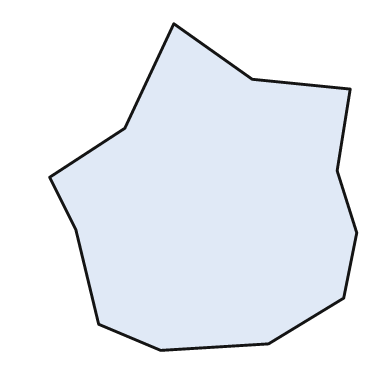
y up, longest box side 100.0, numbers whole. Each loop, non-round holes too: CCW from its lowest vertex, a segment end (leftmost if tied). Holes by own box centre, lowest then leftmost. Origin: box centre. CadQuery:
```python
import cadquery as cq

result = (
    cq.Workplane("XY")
    .moveTo(-13.0, -50.0)
    .lineTo(20.0, -48.0)
    .lineTo(43.0, -34.0)
    .lineTo(47.0, -14.0)
    .lineTo(41.0, 5.0)
    .lineTo(45.0, 30.0)
    .lineTo(15.0, 33.0)
    .lineTo(-9.0, 50.0)
    .lineTo(-24.0, 18.0)
    .lineTo(-47.0, 3.0)
    .lineTo(-39.0, -13.0)
    .lineTo(-32.0, -42.0)
    .close()
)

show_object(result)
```